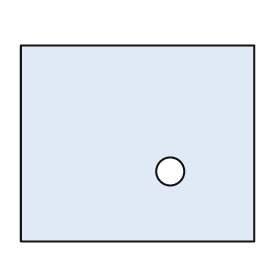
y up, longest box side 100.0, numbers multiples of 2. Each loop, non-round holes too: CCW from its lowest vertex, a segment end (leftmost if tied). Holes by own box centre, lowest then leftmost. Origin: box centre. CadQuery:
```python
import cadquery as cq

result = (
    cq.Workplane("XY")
    .moveTo(-50.0, -42.0)
    .lineTo(50.0, -42.0)
    .lineTo(50.0, 42.0)
    .lineTo(-50.0, 42.0)
    .close()
    .moveTo(14.0, -12.0)
    .circle(6.0)
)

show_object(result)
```